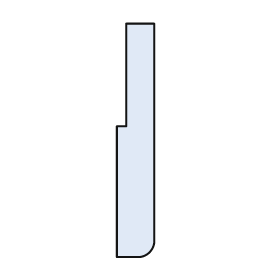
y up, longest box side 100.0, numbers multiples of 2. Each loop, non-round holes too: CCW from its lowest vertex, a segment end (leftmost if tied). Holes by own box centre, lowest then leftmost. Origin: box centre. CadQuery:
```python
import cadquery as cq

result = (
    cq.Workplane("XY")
    .moveTo(-8.0, -50.0)
    .lineTo(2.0, -50.0)
    .threePointArc((6.0, -48.0), (8.0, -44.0))
    .lineTo(8.0, 50.0)
    .lineTo(-4.0, 50.0)
    .lineTo(-4.0, 6.0)
    .lineTo(-8.0, 6.0)
    .close()
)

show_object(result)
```